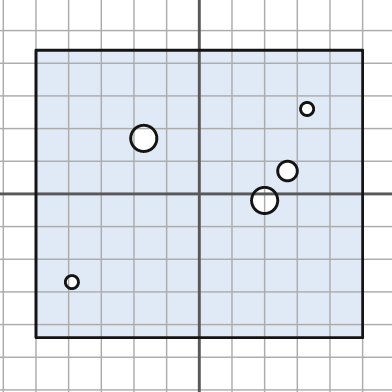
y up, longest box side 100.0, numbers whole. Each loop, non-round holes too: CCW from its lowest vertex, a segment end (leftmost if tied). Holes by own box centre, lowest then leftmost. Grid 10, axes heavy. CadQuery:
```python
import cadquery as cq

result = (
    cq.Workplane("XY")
    .moveTo(-50.0, -44.0)
    .lineTo(50.0, -44.0)
    .lineTo(50.0, 44.0)
    .lineTo(-50.0, 44.0)
    .close()
    .moveTo(-39.0, -27.0)
    .circle(2.0)
    .moveTo(20.0, -2.0)
    .circle(4.0)
    .moveTo(27.0, 7.0)
    .circle(3.0)
    .moveTo(-17.0, 17.0)
    .circle(4.0)
    .moveTo(33.0, 26.0)
    .circle(2.0)
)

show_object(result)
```